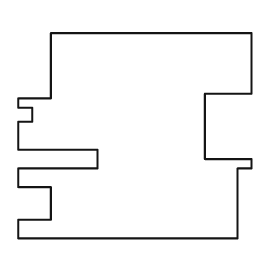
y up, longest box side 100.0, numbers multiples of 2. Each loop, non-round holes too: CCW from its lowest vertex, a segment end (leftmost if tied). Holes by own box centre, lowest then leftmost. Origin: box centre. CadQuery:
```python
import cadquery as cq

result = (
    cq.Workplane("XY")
    .moveTo(-50.0, -44.0)
    .lineTo(44.0, -44.0)
    .lineTo(44.0, -14.0)
    .lineTo(50.0, -14.0)
    .lineTo(50.0, -10.0)
    .lineTo(30.0, -10.0)
    .lineTo(30.0, 18.0)
    .lineTo(50.0, 18.0)
    .lineTo(50.0, 44.0)
    .lineTo(-36.0, 44.0)
    .lineTo(-36.0, 16.0)
    .lineTo(-50.0, 16.0)
    .lineTo(-50.0, 12.0)
    .lineTo(-44.0, 12.0)
    .lineTo(-44.0, 6.0)
    .lineTo(-50.0, 6.0)
    .lineTo(-50.0, -6.0)
    .lineTo(-16.0, -6.0)
    .lineTo(-16.0, -14.0)
    .lineTo(-50.0, -14.0)
    .lineTo(-50.0, -22.0)
    .lineTo(-36.0, -22.0)
    .lineTo(-36.0, -36.0)
    .lineTo(-50.0, -36.0)
    .close()
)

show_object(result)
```